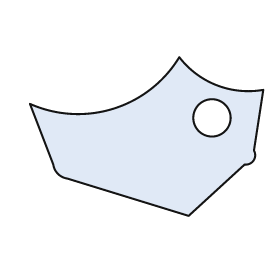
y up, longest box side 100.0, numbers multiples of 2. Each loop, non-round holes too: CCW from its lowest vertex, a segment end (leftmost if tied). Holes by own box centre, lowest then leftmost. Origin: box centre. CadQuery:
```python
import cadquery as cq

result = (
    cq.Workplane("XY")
    .moveTo(18.0, -34.0)
    .lineTo(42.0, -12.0)
    .threePointArc((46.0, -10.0), (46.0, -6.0))
    .lineTo(50.0, 20.0)
    .threePointArc((30.0, 22.0), (14.0, 34.0))
    .threePointArc((-14.0, 12.0), (-50.0, 14.0))
    .lineTo(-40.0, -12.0)
    .threePointArc((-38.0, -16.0), (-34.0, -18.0))
    .close()
    .moveTo(28.0, 8.0)
    .circle(8.0)
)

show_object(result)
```